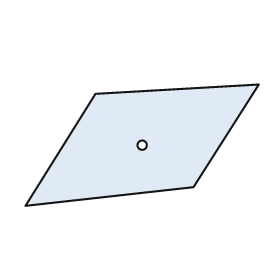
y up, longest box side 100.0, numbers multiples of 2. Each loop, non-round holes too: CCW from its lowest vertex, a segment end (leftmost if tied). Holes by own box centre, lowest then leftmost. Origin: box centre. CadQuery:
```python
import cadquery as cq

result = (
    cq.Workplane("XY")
    .moveTo(-50.0, -26.0)
    .lineTo(22.0, -18.0)
    .lineTo(50.0, 26.0)
    .lineTo(-20.0, 22.0)
    .close()
    .moveTo(0.0, 0.0)
    .circle(2.0)
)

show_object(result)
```